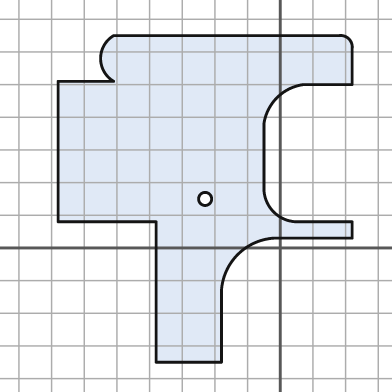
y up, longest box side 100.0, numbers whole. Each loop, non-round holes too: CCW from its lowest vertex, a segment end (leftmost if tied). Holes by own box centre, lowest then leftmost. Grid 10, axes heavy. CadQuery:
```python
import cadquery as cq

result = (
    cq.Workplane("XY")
    .moveTo(-38.0, -35.0)
    .lineTo(-18.0, -35.0)
    .lineTo(-18.0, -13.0)
    .threePointArc((-13.0, -2.0), (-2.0, 3.0))
    .lineTo(22.0, 3.0)
    .lineTo(22.0, 8.0)
    .lineTo(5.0, 8.0)
    .threePointArc((-2.0, 11.0), (-5.0, 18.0))
    .lineTo(-5.0, 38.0)
    .threePointArc((-1.0, 46.0), (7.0, 50.0))
    .lineTo(22.0, 50.0)
    .lineTo(22.0, 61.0)
    .threePointArc((21.0, 64.0), (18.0, 65.0))
    .lineTo(-51.0, 65.0)
    .threePointArc((-55.0, 58.0), (-51.0, 51.0))
    .lineTo(-68.0, 51.0)
    .lineTo(-68.0, 8.0)
    .lineTo(-38.0, 8.0)
    .close()
    .moveTo(-23.0, 15.0)
    .circle(2.0)
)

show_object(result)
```